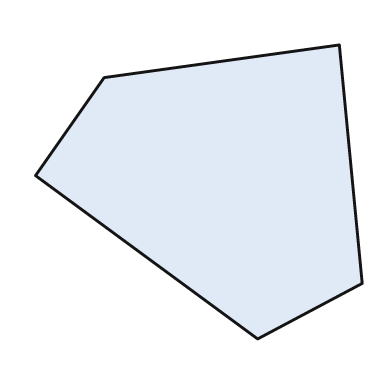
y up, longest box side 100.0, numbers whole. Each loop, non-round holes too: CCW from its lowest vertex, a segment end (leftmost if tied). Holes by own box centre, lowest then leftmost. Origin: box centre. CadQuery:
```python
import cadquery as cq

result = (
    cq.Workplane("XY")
    .moveTo(18.0, -45.0)
    .lineTo(50.0, -28.0)
    .lineTo(43.0, 45.0)
    .lineTo(-29.0, 35.0)
    .lineTo(-50.0, 5.0)
    .close()
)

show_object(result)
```